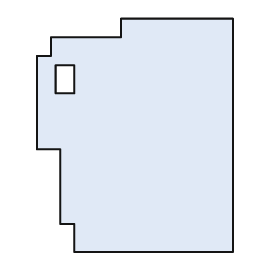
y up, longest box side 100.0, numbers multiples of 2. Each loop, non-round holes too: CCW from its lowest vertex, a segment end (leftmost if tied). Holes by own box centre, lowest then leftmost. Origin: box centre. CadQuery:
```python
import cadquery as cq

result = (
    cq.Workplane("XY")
    .moveTo(-26.0, -50.0)
    .lineTo(42.0, -50.0)
    .lineTo(42.0, 50.0)
    .lineTo(-6.0, 50.0)
    .lineTo(-6.0, 42.0)
    .lineTo(-36.0, 42.0)
    .lineTo(-36.0, 34.0)
    .lineTo(-42.0, 34.0)
    .lineTo(-42.0, -6.0)
    .lineTo(-32.0, -6.0)
    .lineTo(-32.0, -38.0)
    .lineTo(-26.0, -38.0)
    .close()
    .moveTo(-34.0, 18.0)
    .lineTo(-26.0, 18.0)
    .lineTo(-26.0, 30.0)
    .lineTo(-34.0, 30.0)
    .close()
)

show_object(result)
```